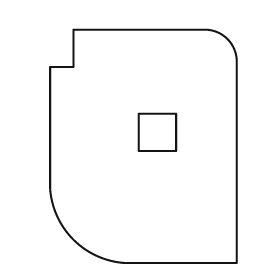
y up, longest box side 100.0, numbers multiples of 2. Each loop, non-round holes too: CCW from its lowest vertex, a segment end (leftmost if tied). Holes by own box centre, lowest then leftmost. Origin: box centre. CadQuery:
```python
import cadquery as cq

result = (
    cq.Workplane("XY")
    .moveTo(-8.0, -50.0)
    .lineTo(40.0, -50.0)
    .lineTo(40.0, 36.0)
    .threePointArc((36.0, 46.0), (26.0, 50.0))
    .lineTo(-30.0, 50.0)
    .lineTo(-30.0, 34.0)
    .lineTo(-40.0, 34.0)
    .lineTo(-40.0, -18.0)
    .threePointArc((-30.0, -40.0), (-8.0, -50.0))
    .close()
    .moveTo(-2.0, -2.0)
    .lineTo(14.0, -2.0)
    .lineTo(14.0, 14.0)
    .lineTo(-2.0, 14.0)
    .close()
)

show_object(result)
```